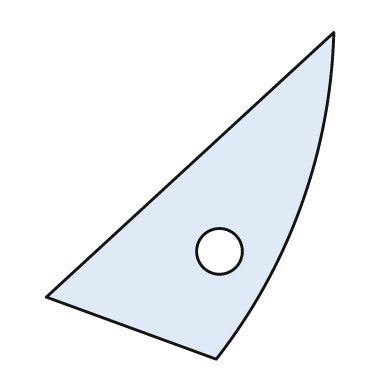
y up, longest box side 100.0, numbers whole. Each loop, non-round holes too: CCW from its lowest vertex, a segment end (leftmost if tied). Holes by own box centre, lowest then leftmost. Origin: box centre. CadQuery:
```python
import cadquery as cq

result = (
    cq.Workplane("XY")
    .moveTo(8.0, -50.0)
    .threePointArc((34.0, -3.0), (44.0, 50.0))
    .lineTo(-44.0, -31.0)
    .close()
    .moveTo(9.0, -17.0)
    .circle(7.0)
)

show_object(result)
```